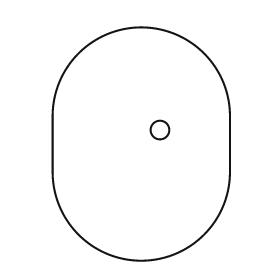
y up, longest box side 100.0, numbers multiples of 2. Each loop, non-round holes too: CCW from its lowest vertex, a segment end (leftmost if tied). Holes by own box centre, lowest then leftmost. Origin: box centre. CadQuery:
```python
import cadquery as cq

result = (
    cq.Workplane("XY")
    .moveTo(-38.0, -12.0)
    .threePointArc((0.0, -50.0), (38.0, -12.0))
    .lineTo(38.0, 12.0)
    .threePointArc((0.0, 50.0), (-38.0, 12.0))
    .close()
    .moveTo(8.0, 6.0)
    .circle(4.0)
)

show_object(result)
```